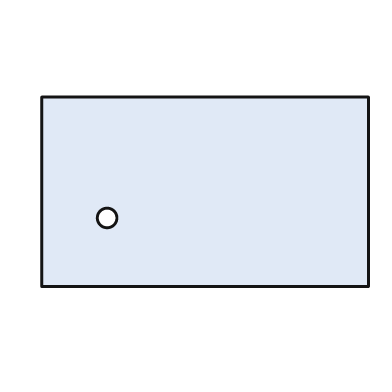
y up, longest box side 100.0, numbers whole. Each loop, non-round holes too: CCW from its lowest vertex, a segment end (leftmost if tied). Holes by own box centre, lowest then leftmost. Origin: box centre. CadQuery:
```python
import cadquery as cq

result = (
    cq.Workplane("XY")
    .moveTo(-50.0, -29.0)
    .lineTo(50.0, -29.0)
    .lineTo(50.0, 29.0)
    .lineTo(-50.0, 29.0)
    .close()
    .moveTo(-30.0, -8.0)
    .circle(3.0)
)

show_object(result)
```